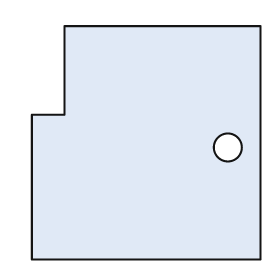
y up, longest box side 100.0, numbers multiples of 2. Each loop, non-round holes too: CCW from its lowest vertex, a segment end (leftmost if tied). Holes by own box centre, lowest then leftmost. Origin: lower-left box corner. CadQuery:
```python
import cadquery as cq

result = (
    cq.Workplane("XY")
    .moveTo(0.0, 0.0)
    .lineTo(98.0, 0.0)
    .lineTo(98.0, 100.0)
    .lineTo(14.0, 100.0)
    .lineTo(14.0, 62.0)
    .lineTo(0.0, 62.0)
    .close()
    .moveTo(84.0, 48.0)
    .circle(6.0)
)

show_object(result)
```